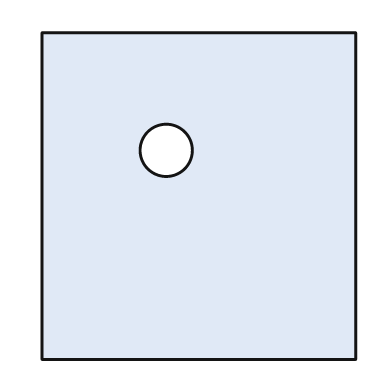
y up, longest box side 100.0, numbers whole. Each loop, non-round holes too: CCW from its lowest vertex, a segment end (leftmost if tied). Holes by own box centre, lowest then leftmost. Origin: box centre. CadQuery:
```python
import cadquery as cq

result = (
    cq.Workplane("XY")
    .moveTo(-48.0, -50.0)
    .lineTo(48.0, -50.0)
    .lineTo(48.0, 50.0)
    .lineTo(-48.0, 50.0)
    .close()
    .moveTo(-10.0, 14.0)
    .circle(8.0)
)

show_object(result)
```